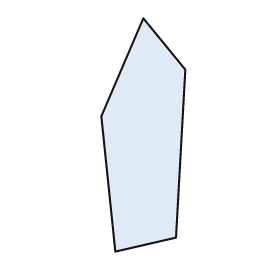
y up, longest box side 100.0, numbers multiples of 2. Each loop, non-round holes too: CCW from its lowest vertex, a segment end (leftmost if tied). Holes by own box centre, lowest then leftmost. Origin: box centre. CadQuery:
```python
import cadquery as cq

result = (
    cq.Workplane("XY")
    .moveTo(-12.0, -50.0)
    .lineTo(14.0, -44.0)
    .lineTo(18.0, 28.0)
    .lineTo(0.0, 50.0)
    .lineTo(-18.0, 8.0)
    .close()
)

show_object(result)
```